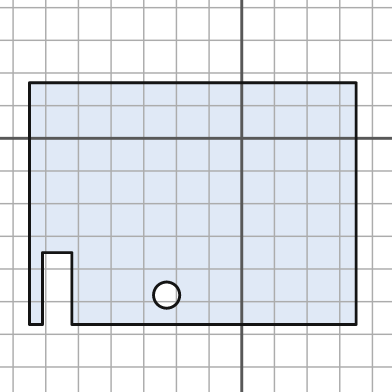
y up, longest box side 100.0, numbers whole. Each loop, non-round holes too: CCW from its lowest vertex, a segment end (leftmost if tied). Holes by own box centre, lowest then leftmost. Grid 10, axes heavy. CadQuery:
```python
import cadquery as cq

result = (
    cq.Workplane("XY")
    .moveTo(-65.0, -57.0)
    .lineTo(-61.0, -57.0)
    .lineTo(-61.0, -35.0)
    .lineTo(-52.0, -35.0)
    .lineTo(-52.0, -57.0)
    .lineTo(35.0, -57.0)
    .lineTo(35.0, 17.0)
    .lineTo(-65.0, 17.0)
    .close()
    .moveTo(-23.0, -48.0)
    .circle(4.0)
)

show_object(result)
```